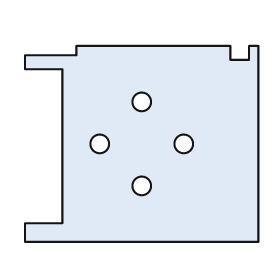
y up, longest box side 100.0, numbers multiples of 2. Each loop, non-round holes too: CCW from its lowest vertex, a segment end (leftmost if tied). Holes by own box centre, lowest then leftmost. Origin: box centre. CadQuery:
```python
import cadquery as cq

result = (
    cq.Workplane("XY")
    .moveTo(-50.0, -42.0)
    .lineTo(50.0, -42.0)
    .lineTo(50.0, 42.0)
    .lineTo(46.0, 42.0)
    .lineTo(46.0, 36.0)
    .lineTo(38.0, 36.0)
    .lineTo(38.0, 42.0)
    .lineTo(-28.0, 42.0)
    .lineTo(-28.0, 38.0)
    .lineTo(-50.0, 38.0)
    .lineTo(-50.0, 32.0)
    .lineTo(-34.0, 32.0)
    .lineTo(-34.0, -34.0)
    .lineTo(-50.0, -34.0)
    .close()
    .moveTo(0.0, -18.0)
    .circle(4.0)
    .moveTo(-18.0, 0.0)
    .circle(4.0)
    .moveTo(18.0, 0.0)
    .circle(4.0)
    .moveTo(0.0, 18.0)
    .circle(4.0)
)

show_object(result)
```